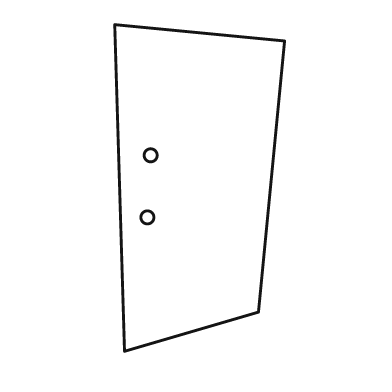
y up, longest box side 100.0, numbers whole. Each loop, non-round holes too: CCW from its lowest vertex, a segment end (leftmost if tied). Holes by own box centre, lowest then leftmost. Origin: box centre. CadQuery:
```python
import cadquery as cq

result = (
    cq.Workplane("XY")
    .moveTo(-23.0, -50.0)
    .lineTo(18.0, -38.0)
    .lineTo(26.0, 45.0)
    .lineTo(-26.0, 50.0)
    .close()
    .moveTo(-16.0, -9.0)
    .circle(2.0)
    .moveTo(-15.0, 10.0)
    .circle(2.0)
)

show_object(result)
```